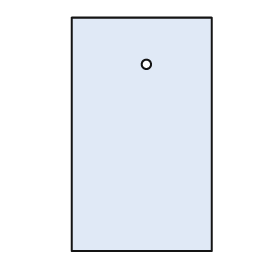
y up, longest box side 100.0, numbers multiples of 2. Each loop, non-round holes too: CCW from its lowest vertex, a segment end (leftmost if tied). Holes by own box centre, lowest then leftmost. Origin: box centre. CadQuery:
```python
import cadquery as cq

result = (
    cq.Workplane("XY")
    .moveTo(-30.0, -50.0)
    .lineTo(30.0, -50.0)
    .lineTo(30.0, 50.0)
    .lineTo(-30.0, 50.0)
    .close()
    .moveTo(2.0, 30.0)
    .circle(2.0)
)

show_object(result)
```